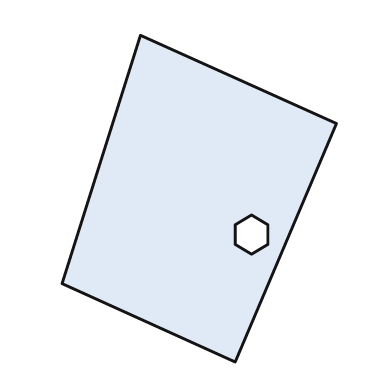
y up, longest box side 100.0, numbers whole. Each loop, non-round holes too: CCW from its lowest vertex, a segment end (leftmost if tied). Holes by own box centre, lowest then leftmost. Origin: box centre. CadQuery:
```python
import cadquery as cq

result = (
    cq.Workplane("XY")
    .moveTo(11.0, -50.0)
    .lineTo(42.0, 23.0)
    .lineTo(-18.0, 50.0)
    .lineTo(-42.0, -26.0)
    .close()
    .moveTo(16.0, -17.0)
    .lineTo(21.0, -14.0)
    .lineTo(21.0, -8.0)
    .lineTo(16.0, -5.0)
    .lineTo(11.0, -8.0)
    .lineTo(11.0, -14.0)
    .close()
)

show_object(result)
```